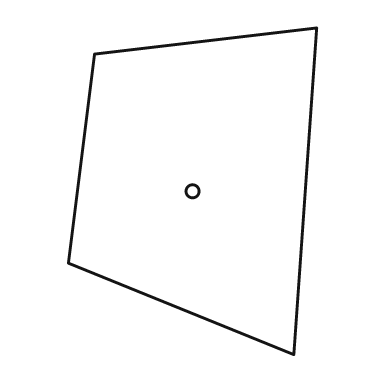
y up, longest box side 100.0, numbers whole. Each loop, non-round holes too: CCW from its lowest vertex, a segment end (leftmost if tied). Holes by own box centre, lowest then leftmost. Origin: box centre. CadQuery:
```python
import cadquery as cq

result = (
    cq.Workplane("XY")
    .moveTo(31.0, -50.0)
    .lineTo(38.0, 50.0)
    .lineTo(-30.0, 42.0)
    .lineTo(-38.0, -22.0)
    .close()
    .moveTo(0.0, 0.0)
    .circle(2.0)
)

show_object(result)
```